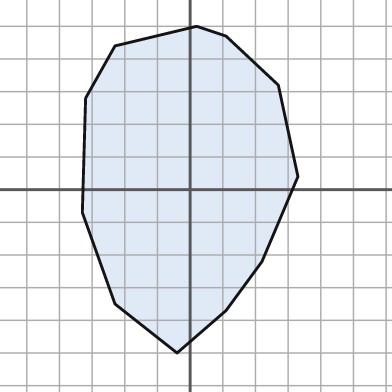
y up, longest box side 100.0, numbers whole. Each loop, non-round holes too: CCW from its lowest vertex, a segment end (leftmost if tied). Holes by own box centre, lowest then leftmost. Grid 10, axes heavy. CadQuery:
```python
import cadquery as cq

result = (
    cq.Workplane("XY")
    .moveTo(-4.0, -50.0)
    .lineTo(11.0, -37.0)
    .lineTo(22.0, -22.0)
    .lineTo(33.0, 4.0)
    .lineTo(27.0, 32.0)
    .lineTo(11.0, 47.0)
    .lineTo(2.0, 50.0)
    .lineTo(-23.0, 44.0)
    .lineTo(-32.0, 28.0)
    .lineTo(-33.0, -7.0)
    .lineTo(-23.0, -35.0)
    .close()
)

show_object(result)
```